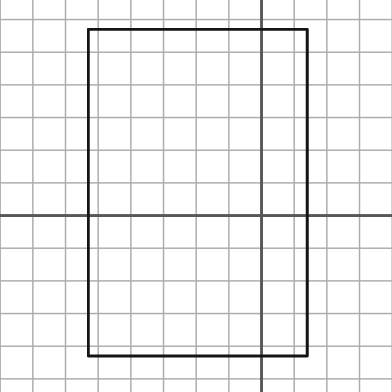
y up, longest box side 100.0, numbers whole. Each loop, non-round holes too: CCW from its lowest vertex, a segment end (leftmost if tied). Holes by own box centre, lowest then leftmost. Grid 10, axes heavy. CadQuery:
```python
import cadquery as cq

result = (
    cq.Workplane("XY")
    .moveTo(-53.0, -43.0)
    .lineTo(14.0, -43.0)
    .lineTo(14.0, 57.0)
    .lineTo(-53.0, 57.0)
    .close()
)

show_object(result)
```